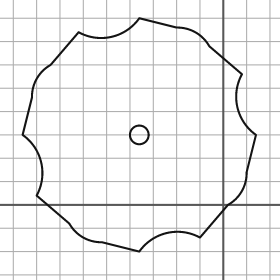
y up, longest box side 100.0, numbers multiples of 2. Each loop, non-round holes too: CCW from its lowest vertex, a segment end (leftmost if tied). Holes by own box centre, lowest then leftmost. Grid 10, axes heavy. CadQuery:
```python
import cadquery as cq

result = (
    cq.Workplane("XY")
    .moveTo(-36.0, -20.0)
    .threePointArc((-24.0, -12.0), (-10.0, -14.0))
    .lineTo(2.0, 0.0)
    .threePointArc((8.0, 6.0), (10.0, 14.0))
    .lineTo(14.0, 30.0)
    .threePointArc((6.0, 42.0), (8.0, 56.0))
    .lineTo(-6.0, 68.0)
    .threePointArc((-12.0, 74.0), (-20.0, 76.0))
    .lineTo(-36.0, 80.0)
    .threePointArc((-48.0, 72.0), (-62.0, 74.0))
    .lineTo(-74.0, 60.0)
    .threePointArc((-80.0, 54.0), (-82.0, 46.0))
    .lineTo(-86.0, 30.0)
    .threePointArc((-78.0, 18.0), (-80.0, 4.0))
    .lineTo(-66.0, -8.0)
    .threePointArc((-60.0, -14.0), (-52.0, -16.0))
    .close()
    .moveTo(-36.0, 30.0)
    .circle(4.0)
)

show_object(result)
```